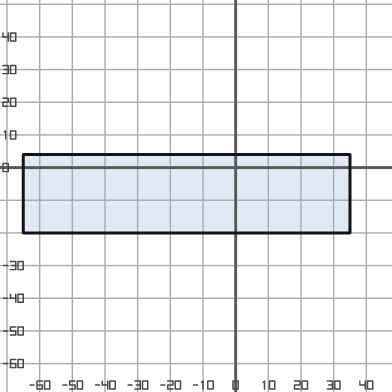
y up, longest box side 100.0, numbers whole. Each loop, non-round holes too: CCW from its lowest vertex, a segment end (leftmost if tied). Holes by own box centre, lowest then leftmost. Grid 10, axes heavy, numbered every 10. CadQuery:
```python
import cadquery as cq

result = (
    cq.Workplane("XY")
    .moveTo(-65.0, -20.0)
    .lineTo(35.0, -20.0)
    .lineTo(35.0, 4.0)
    .lineTo(-65.0, 4.0)
    .close()
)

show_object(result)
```